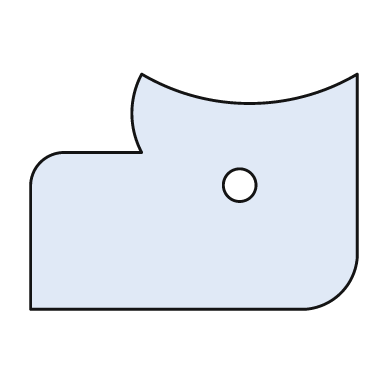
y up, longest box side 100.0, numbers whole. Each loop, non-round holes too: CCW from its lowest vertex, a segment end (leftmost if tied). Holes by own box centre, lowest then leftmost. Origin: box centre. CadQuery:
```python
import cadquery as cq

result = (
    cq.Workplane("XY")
    .moveTo(-50.0, -36.0)
    .lineTo(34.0, -36.0)
    .threePointArc((45.0, -31.0), (50.0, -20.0))
    .lineTo(50.0, 36.0)
    .threePointArc((17.0, 27.0), (-16.0, 36.0))
    .threePointArc((-19.0, 24.0), (-16.0, 12.0))
    .lineTo(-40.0, 12.0)
    .threePointArc((-47.0, 9.0), (-50.0, 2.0))
    .close()
    .moveTo(14.0, 2.0)
    .circle(5.0)
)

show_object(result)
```